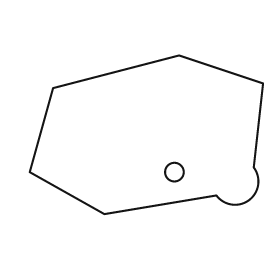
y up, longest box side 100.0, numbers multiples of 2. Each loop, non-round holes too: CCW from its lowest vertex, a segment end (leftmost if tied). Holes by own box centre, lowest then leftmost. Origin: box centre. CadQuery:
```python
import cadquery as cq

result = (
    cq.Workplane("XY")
    .moveTo(-18.0, -34.0)
    .lineTo(30.0, -26.0)
    .threePointArc((44.0, -28.0), (46.0, -14.0))
    .lineTo(50.0, 22.0)
    .lineTo(14.0, 34.0)
    .lineTo(-40.0, 20.0)
    .lineTo(-50.0, -16.0)
    .close()
    .moveTo(12.0, -16.0)
    .circle(4.0)
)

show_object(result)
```